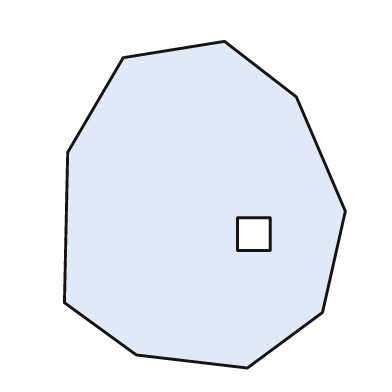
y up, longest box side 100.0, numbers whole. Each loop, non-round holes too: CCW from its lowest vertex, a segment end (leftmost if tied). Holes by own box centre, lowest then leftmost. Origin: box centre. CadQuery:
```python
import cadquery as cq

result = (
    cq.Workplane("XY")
    .moveTo(13.0, -50.0)
    .lineTo(36.0, -33.0)
    .lineTo(43.0, -2.0)
    .lineTo(28.0, 33.0)
    .lineTo(6.0, 50.0)
    .lineTo(-25.0, 45.0)
    .lineTo(-42.0, 16.0)
    .lineTo(-43.0, -30.0)
    .lineTo(-21.0, -46.0)
    .close()
    .moveTo(10.0, -14.0)
    .lineTo(20.0, -14.0)
    .lineTo(20.0, -4.0)
    .lineTo(10.0, -4.0)
    .close()
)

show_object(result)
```